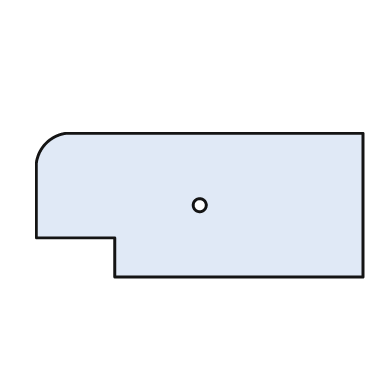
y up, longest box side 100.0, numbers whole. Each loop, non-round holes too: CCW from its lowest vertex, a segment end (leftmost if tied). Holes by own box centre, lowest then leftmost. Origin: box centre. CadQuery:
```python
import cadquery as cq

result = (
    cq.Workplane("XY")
    .moveTo(-26.0, -22.0)
    .lineTo(50.0, -22.0)
    .lineTo(50.0, 22.0)
    .lineTo(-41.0, 22.0)
    .threePointArc((-47.0, 19.0), (-50.0, 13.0))
    .lineTo(-50.0, -10.0)
    .lineTo(-26.0, -10.0)
    .close()
    .moveTo(0.0, 0.0)
    .circle(2.0)
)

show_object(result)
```